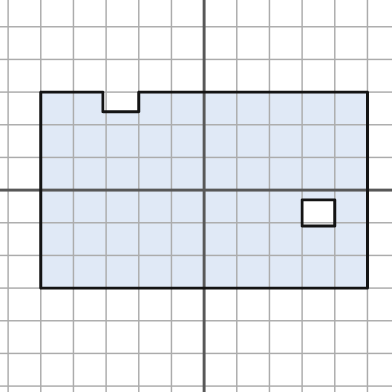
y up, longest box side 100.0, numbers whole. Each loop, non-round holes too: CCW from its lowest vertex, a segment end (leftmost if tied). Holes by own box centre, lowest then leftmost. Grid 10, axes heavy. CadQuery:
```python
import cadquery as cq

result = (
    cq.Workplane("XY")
    .moveTo(-50.0, -30.0)
    .lineTo(50.0, -30.0)
    .lineTo(50.0, 30.0)
    .lineTo(-20.0, 30.0)
    .lineTo(-20.0, 24.0)
    .lineTo(-31.0, 24.0)
    .lineTo(-31.0, 30.0)
    .lineTo(-50.0, 30.0)
    .close()
    .moveTo(30.0, -11.0)
    .lineTo(40.0, -11.0)
    .lineTo(40.0, -3.0)
    .lineTo(30.0, -3.0)
    .close()
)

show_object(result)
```